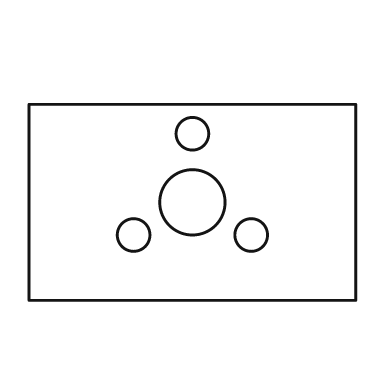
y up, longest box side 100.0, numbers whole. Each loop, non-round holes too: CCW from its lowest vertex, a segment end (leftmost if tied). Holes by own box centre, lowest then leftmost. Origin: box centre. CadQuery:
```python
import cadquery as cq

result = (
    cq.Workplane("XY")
    .moveTo(-50.0, -30.0)
    .lineTo(50.0, -30.0)
    .lineTo(50.0, 30.0)
    .lineTo(-50.0, 30.0)
    .close()
    .moveTo(-18.0, -10.0)
    .circle(5.0)
    .moveTo(18.0, -10.0)
    .circle(5.0)
    .moveTo(0.0, 0.0)
    .circle(10.0)
    .moveTo(0.0, 21.0)
    .circle(5.0)
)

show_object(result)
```